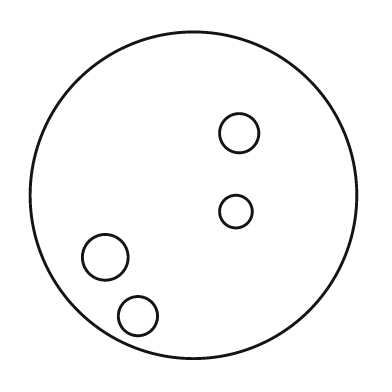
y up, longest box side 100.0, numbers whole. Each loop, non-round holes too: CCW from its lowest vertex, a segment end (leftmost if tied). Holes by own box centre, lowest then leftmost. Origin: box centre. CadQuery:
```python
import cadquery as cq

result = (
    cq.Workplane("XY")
    .moveTo(0.0, 0.0)
    .circle(50.0)
    .moveTo(-17.0, -37.0)
    .circle(6.0)
    .moveTo(-27.0, -19.0)
    .circle(7.0)
    .moveTo(13.0, -5.0)
    .circle(5.0)
    .moveTo(14.0, 19.0)
    .circle(6.0)
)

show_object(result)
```